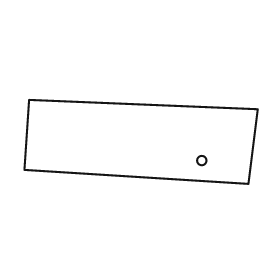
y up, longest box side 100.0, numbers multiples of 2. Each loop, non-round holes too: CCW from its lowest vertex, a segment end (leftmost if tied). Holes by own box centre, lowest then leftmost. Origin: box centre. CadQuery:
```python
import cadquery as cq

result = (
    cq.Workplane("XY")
    .moveTo(46.0, -18.0)
    .lineTo(50.0, 14.0)
    .lineTo(-48.0, 18.0)
    .lineTo(-50.0, -12.0)
    .close()
    .moveTo(26.0, -8.0)
    .circle(2.0)
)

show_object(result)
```